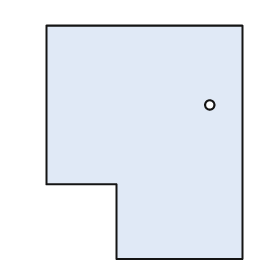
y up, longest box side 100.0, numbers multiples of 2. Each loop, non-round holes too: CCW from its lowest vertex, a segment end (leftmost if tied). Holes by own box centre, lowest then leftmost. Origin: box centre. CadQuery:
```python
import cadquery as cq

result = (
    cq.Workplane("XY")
    .moveTo(-12.0, -50.0)
    .lineTo(42.0, -50.0)
    .lineTo(42.0, 50.0)
    .lineTo(-42.0, 50.0)
    .lineTo(-42.0, -18.0)
    .lineTo(-12.0, -18.0)
    .close()
    .moveTo(28.0, 16.0)
    .circle(2.0)
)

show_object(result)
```